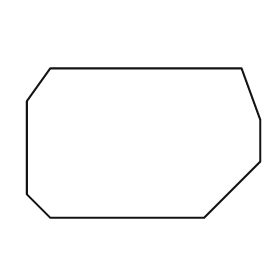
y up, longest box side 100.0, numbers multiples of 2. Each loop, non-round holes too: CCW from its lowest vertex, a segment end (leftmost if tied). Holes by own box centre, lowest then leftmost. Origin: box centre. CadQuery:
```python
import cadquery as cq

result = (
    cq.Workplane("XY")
    .moveTo(-40.0, -32.0)
    .lineTo(26.0, -32.0)
    .lineTo(50.0, -8.0)
    .lineTo(50.0, 10.0)
    .lineTo(42.0, 32.0)
    .lineTo(-40.0, 32.0)
    .lineTo(-50.0, 18.0)
    .lineTo(-50.0, -22.0)
    .close()
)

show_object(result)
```